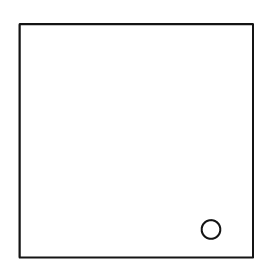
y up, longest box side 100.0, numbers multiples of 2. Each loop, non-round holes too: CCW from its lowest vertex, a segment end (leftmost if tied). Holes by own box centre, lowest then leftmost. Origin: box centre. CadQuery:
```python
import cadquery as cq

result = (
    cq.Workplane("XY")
    .moveTo(-50.0, -50.0)
    .lineTo(50.0, -50.0)
    .lineTo(50.0, 50.0)
    .lineTo(-50.0, 50.0)
    .close()
    .moveTo(32.0, -38.0)
    .circle(4.0)
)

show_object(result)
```